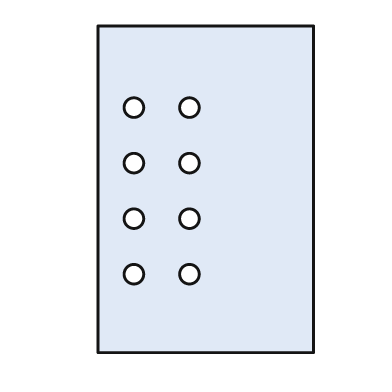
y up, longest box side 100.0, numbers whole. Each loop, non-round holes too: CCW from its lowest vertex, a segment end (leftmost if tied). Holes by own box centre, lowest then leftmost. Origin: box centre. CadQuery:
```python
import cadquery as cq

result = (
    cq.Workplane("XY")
    .moveTo(-33.0, -50.0)
    .lineTo(33.0, -50.0)
    .lineTo(33.0, 50.0)
    .lineTo(-33.0, 50.0)
    .close()
    .moveTo(-22.0, -26.0)
    .circle(3.0)
    .moveTo(-5.0, -26.0)
    .circle(3.0)
    .moveTo(-22.0, -9.0)
    .circle(3.0)
    .moveTo(-5.0, -9.0)
    .circle(3.0)
    .moveTo(-22.0, 8.0)
    .circle(3.0)
    .moveTo(-5.0, 8.0)
    .circle(3.0)
    .moveTo(-22.0, 25.0)
    .circle(3.0)
    .moveTo(-5.0, 25.0)
    .circle(3.0)
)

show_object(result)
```